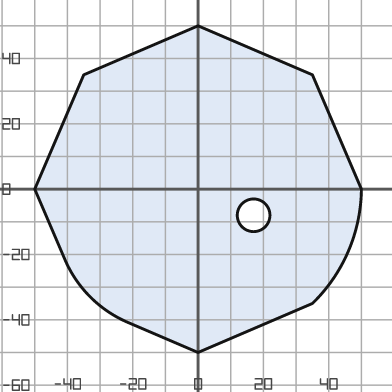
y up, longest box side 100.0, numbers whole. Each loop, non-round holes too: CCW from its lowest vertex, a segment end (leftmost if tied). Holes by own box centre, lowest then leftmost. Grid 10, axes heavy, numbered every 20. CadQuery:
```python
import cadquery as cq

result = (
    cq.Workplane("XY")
    .moveTo(0.0, -50.0)
    .lineTo(35.0, -35.0)
    .threePointArc((46.0, -19.0), (50.0, 0.0))
    .lineTo(35.0, 35.0)
    .lineTo(0.0, 50.0)
    .lineTo(-35.0, 35.0)
    .lineTo(-50.0, 0.0)
    .lineTo(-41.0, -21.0)
    .threePointArc((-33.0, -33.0), (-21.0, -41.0))
    .close()
    .moveTo(17.0, -8.0)
    .circle(5.0)
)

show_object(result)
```